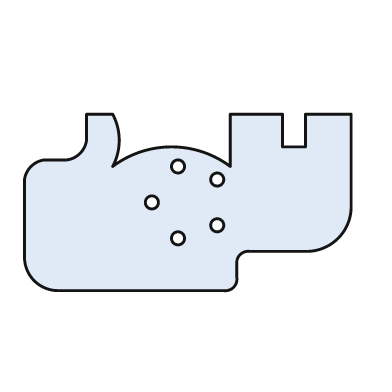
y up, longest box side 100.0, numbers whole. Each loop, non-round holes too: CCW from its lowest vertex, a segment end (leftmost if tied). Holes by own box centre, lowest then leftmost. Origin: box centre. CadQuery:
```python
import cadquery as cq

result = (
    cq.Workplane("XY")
    .moveTo(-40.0, -27.0)
    .lineTo(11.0, -27.0)
    .threePointArc((14.0, -26.0), (15.0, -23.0))
    .lineTo(15.0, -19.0)
    .threePointArc((16.0, -16.0), (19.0, -15.0))
    .lineTo(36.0, -15.0)
    .threePointArc((46.0, -11.0), (50.0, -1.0))
    .lineTo(50.0, 27.0)
    .lineTo(36.0, 27.0)
    .lineTo(36.0, 17.0)
    .lineTo(29.0, 17.0)
    .lineTo(29.0, 27.0)
    .lineTo(13.0, 27.0)
    .lineTo(13.0, 11.0)
    .threePointArc((-5.0, 17.0), (-23.0, 11.0))
    .threePointArc((-21.0, 19.0), (-23.0, 27.0))
    .lineTo(-31.0, 27.0)
    .lineTo(-31.0, 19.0)
    .threePointArc((-33.0, 15.0), (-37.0, 13.0))
    .lineTo(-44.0, 13.0)
    .threePointArc((-48.0, 11.0), (-50.0, 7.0))
    .lineTo(-50.0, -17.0)
    .threePointArc((-47.0, -24.0), (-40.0, -27.0))
    .close()
    .moveTo(-3.0, -11.0)
    .circle(2.0)
    .moveTo(9.0, -7.0)
    .circle(2.0)
    .moveTo(-11.0, 0.0)
    .circle(2.0)
    .moveTo(9.0, 7.0)
    .circle(2.0)
    .moveTo(-3.0, 11.0)
    .circle(2.0)
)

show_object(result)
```